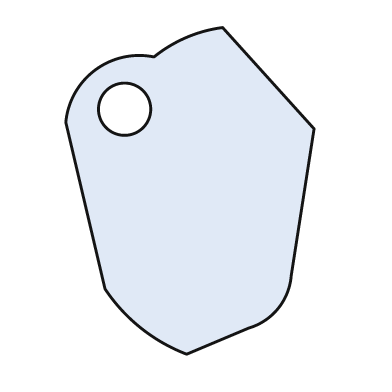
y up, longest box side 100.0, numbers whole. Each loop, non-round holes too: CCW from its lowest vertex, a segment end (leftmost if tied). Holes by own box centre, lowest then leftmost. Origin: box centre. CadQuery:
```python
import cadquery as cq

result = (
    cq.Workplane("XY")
    .moveTo(-1.0, -50.0)
    .lineTo(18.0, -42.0)
    .threePointArc((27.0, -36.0), (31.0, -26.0))
    .lineTo(38.0, 19.0)
    .lineTo(10.0, 50.0)
    .threePointArc((-1.0, 47.0), (-11.0, 41.0))
    .threePointArc((-29.0, 37.0), (-38.0, 21.0))
    .lineTo(-26.0, -30.0)
    .threePointArc((-15.0, -42.0), (-1.0, -50.0))
    .close()
    .moveTo(-20.0, 25.0)
    .circle(8.0)
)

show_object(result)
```